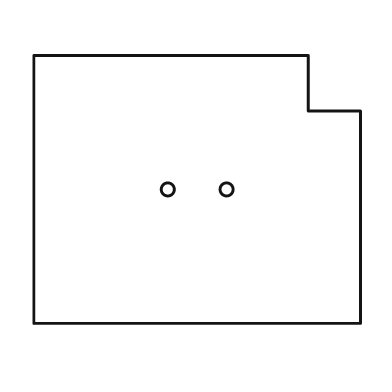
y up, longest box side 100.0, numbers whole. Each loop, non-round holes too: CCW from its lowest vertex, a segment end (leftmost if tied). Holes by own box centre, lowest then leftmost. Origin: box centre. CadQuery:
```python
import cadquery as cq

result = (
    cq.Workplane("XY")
    .moveTo(-50.0, -41.0)
    .lineTo(50.0, -41.0)
    .lineTo(50.0, 24.0)
    .lineTo(34.0, 24.0)
    .lineTo(34.0, 41.0)
    .lineTo(-50.0, 41.0)
    .close()
    .moveTo(-9.0, 0.0)
    .circle(2.0)
    .moveTo(9.0, 0.0)
    .circle(2.0)
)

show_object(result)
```